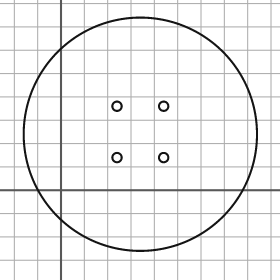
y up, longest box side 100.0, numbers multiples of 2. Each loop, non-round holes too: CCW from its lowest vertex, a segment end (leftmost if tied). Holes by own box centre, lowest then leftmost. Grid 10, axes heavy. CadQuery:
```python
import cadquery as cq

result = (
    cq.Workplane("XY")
    .moveTo(34.0, 24.0)
    .circle(50.0)
    .moveTo(24.0, 14.0)
    .circle(2.0)
    .moveTo(44.0, 14.0)
    .circle(2.0)
    .moveTo(24.0, 36.0)
    .circle(2.0)
    .moveTo(44.0, 36.0)
    .circle(2.0)
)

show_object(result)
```